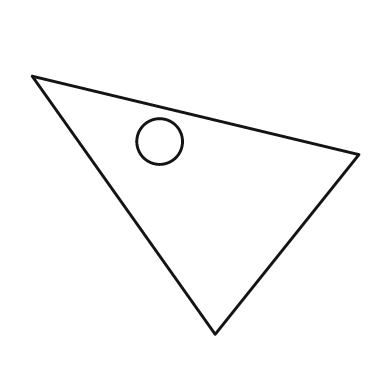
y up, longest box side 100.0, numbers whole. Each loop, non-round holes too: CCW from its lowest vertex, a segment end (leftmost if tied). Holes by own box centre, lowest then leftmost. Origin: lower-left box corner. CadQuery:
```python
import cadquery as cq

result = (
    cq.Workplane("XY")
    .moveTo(56.0, 0.0)
    .lineTo(100.0, 55.0)
    .lineTo(0.0, 79.0)
    .close()
    .moveTo(39.0, 59.0)
    .circle(7.0)
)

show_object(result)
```